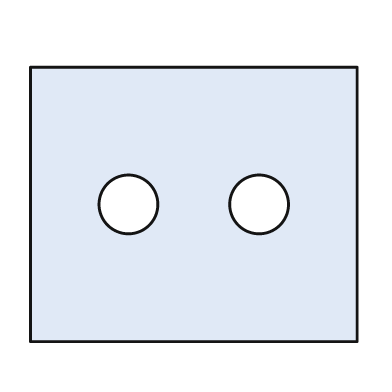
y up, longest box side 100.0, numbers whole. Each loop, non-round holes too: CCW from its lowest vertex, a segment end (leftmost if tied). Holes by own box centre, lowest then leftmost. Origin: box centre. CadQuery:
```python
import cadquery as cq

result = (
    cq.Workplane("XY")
    .moveTo(-50.0, -42.0)
    .lineTo(50.0, -42.0)
    .lineTo(50.0, 42.0)
    .lineTo(-50.0, 42.0)
    .close()
    .moveTo(-20.0, 0.0)
    .circle(9.0)
    .moveTo(20.0, 0.0)
    .circle(9.0)
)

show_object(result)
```